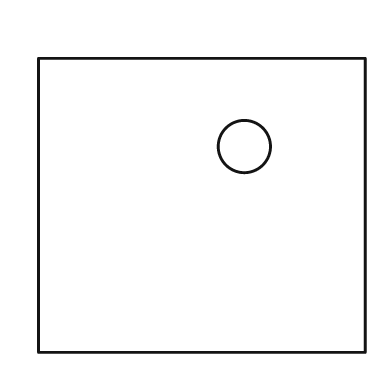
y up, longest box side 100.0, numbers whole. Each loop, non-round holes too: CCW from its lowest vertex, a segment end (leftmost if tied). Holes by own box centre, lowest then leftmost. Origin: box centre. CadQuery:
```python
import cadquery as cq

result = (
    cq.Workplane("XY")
    .moveTo(-50.0, -45.0)
    .lineTo(50.0, -45.0)
    .lineTo(50.0, 45.0)
    .lineTo(-50.0, 45.0)
    .close()
    .moveTo(13.0, 18.0)
    .circle(8.0)
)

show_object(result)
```